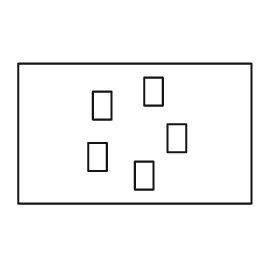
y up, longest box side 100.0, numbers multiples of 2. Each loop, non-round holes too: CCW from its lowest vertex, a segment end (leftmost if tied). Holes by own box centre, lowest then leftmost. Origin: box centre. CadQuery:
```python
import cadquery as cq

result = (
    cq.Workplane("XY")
    .moveTo(-50.0, -30.0)
    .lineTo(50.0, -30.0)
    .lineTo(50.0, 30.0)
    .lineTo(-50.0, 30.0)
    .close()
    .moveTo(0.0, -24.0)
    .lineTo(8.0, -24.0)
    .lineTo(8.0, -12.0)
    .lineTo(0.0, -12.0)
    .close()
    .moveTo(-20.0, -16.0)
    .lineTo(-12.0, -16.0)
    .lineTo(-12.0, -4.0)
    .lineTo(-20.0, -4.0)
    .close()
    .moveTo(14.0, -8.0)
    .lineTo(22.0, -8.0)
    .lineTo(22.0, 4.0)
    .lineTo(14.0, 4.0)
    .close()
    .moveTo(-18.0, 6.0)
    .lineTo(-10.0, 6.0)
    .lineTo(-10.0, 18.0)
    .lineTo(-18.0, 18.0)
    .close()
    .moveTo(4.0, 12.0)
    .lineTo(12.0, 12.0)
    .lineTo(12.0, 24.0)
    .lineTo(4.0, 24.0)
    .close()
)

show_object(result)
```